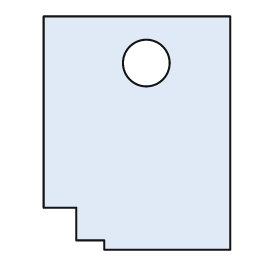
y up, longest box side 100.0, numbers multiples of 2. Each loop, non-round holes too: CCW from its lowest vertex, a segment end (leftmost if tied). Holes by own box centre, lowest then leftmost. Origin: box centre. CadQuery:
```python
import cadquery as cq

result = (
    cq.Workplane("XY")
    .moveTo(-14.0, -50.0)
    .lineTo(40.0, -50.0)
    .lineTo(40.0, 50.0)
    .lineTo(-40.0, 50.0)
    .lineTo(-40.0, -32.0)
    .lineTo(-26.0, -32.0)
    .lineTo(-26.0, -46.0)
    .lineTo(-14.0, -46.0)
    .close()
    .moveTo(4.0, 30.0)
    .circle(10.0)
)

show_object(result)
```